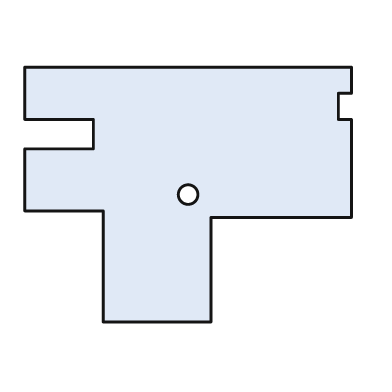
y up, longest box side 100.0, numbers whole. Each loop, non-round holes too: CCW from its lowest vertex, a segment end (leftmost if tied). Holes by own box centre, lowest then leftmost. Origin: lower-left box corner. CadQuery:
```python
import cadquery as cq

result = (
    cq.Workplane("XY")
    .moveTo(24.0, 0.0)
    .lineTo(57.0, 0.0)
    .lineTo(57.0, 32.0)
    .lineTo(100.0, 32.0)
    .lineTo(100.0, 62.0)
    .lineTo(96.0, 62.0)
    .lineTo(96.0, 70.0)
    .lineTo(100.0, 70.0)
    .lineTo(100.0, 78.0)
    .lineTo(0.0, 78.0)
    .lineTo(0.0, 62.0)
    .lineTo(21.0, 62.0)
    .lineTo(21.0, 53.0)
    .lineTo(0.0, 53.0)
    .lineTo(0.0, 34.0)
    .lineTo(24.0, 34.0)
    .close()
    .moveTo(50.0, 39.0)
    .circle(3.0)
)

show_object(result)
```